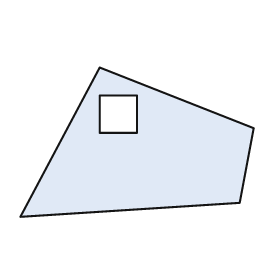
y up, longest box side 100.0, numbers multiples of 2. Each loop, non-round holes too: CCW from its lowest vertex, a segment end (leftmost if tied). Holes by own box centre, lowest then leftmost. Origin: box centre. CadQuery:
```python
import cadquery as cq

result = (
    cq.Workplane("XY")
    .moveTo(-50.0, -32.0)
    .lineTo(44.0, -26.0)
    .lineTo(50.0, 6.0)
    .lineTo(-16.0, 32.0)
    .close()
    .moveTo(-16.0, 4.0)
    .lineTo(0.0, 4.0)
    .lineTo(0.0, 20.0)
    .lineTo(-16.0, 20.0)
    .close()
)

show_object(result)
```